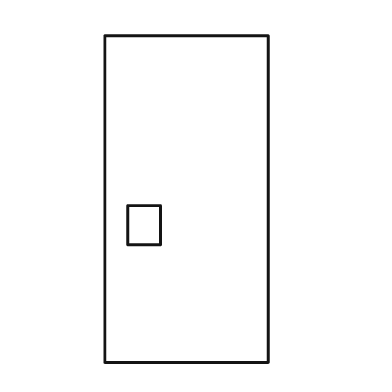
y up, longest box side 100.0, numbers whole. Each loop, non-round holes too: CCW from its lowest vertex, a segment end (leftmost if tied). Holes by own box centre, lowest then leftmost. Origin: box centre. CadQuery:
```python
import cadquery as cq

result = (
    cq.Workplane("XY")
    .moveTo(-25.0, -50.0)
    .lineTo(25.0, -50.0)
    .lineTo(25.0, 50.0)
    .lineTo(-25.0, 50.0)
    .close()
    .moveTo(-18.0, -14.0)
    .lineTo(-8.0, -14.0)
    .lineTo(-8.0, -2.0)
    .lineTo(-18.0, -2.0)
    .close()
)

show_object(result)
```